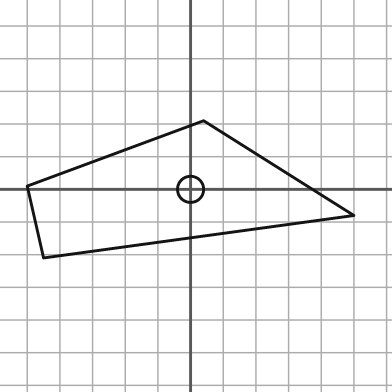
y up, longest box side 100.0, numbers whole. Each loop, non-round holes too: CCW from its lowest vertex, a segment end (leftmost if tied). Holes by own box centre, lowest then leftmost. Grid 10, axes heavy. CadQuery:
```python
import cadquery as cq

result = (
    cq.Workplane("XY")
    .moveTo(-45.0, -21.0)
    .lineTo(50.0, -8.0)
    .lineTo(4.0, 21.0)
    .lineTo(-50.0, 1.0)
    .close()
    .moveTo(0.0, 0.0)
    .circle(4.0)
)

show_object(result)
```